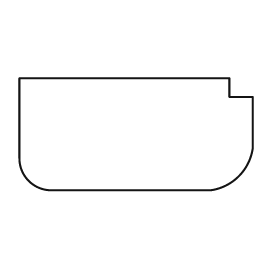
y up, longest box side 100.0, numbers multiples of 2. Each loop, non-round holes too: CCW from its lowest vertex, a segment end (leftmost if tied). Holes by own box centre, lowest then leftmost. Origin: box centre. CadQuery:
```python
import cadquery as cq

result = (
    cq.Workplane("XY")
    .moveTo(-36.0, -24.0)
    .lineTo(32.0, -24.0)
    .threePointArc((44.0, -18.0), (50.0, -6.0))
    .lineTo(50.0, 16.0)
    .lineTo(40.0, 16.0)
    .lineTo(40.0, 24.0)
    .lineTo(-50.0, 24.0)
    .lineTo(-50.0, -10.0)
    .threePointArc((-46.0, -20.0), (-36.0, -24.0))
    .close()
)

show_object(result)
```